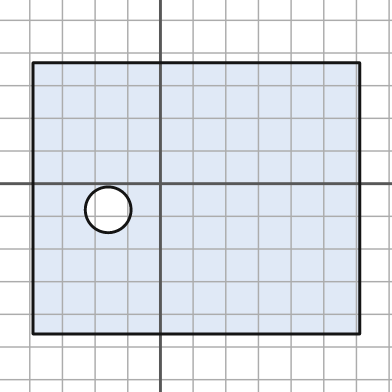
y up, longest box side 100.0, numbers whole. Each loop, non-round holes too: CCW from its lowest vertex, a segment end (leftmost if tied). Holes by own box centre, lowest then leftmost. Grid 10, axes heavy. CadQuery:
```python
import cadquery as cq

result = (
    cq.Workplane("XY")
    .moveTo(-39.0, -46.0)
    .lineTo(61.0, -46.0)
    .lineTo(61.0, 37.0)
    .lineTo(-39.0, 37.0)
    .close()
    .moveTo(-16.0, -8.0)
    .circle(7.0)
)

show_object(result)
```